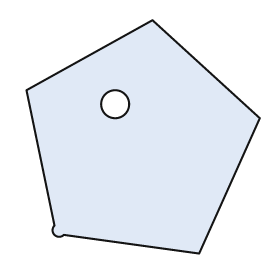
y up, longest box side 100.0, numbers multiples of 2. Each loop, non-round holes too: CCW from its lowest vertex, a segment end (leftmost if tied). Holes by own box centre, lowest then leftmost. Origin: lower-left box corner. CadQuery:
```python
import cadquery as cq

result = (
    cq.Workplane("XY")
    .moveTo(74.0, 0.0)
    .lineTo(100.0, 58.0)
    .lineTo(54.0, 100.0)
    .lineTo(0.0, 70.0)
    .lineTo(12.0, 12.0)
    .threePointArc((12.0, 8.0), (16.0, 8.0))
    .close()
    .moveTo(38.0, 64.0)
    .circle(6.0)
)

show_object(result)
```